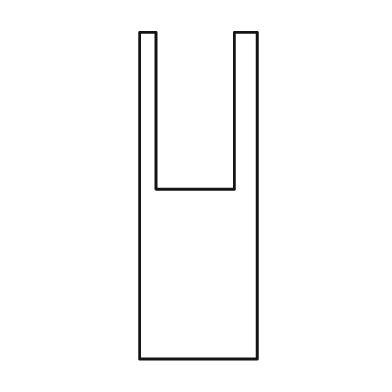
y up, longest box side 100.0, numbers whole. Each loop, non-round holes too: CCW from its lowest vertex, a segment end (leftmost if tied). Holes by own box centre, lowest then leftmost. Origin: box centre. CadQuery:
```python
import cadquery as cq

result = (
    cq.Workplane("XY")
    .moveTo(-18.0, -50.0)
    .lineTo(18.0, -50.0)
    .lineTo(18.0, 50.0)
    .lineTo(11.0, 50.0)
    .lineTo(11.0, 2.0)
    .lineTo(-13.0, 2.0)
    .lineTo(-13.0, 50.0)
    .lineTo(-18.0, 50.0)
    .close()
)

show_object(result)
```